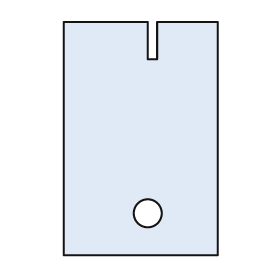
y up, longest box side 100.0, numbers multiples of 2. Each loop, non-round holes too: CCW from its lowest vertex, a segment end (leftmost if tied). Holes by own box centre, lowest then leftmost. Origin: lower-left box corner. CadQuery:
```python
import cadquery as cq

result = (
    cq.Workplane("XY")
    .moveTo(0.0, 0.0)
    .lineTo(66.0, 0.0)
    .lineTo(66.0, 100.0)
    .lineTo(40.0, 100.0)
    .lineTo(40.0, 84.0)
    .lineTo(36.0, 84.0)
    .lineTo(36.0, 100.0)
    .lineTo(0.0, 100.0)
    .close()
    .moveTo(36.0, 18.0)
    .circle(6.0)
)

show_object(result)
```